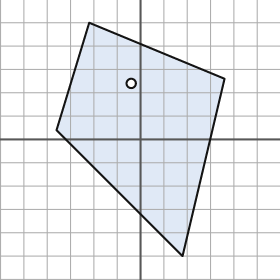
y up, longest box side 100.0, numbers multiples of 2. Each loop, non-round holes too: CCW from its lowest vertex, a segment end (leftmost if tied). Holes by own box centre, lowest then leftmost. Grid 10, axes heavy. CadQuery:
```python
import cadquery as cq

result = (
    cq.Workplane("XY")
    .moveTo(18.0, -50.0)
    .lineTo(36.0, 26.0)
    .lineTo(-22.0, 50.0)
    .lineTo(-36.0, 4.0)
    .close()
    .moveTo(-4.0, 24.0)
    .circle(2.0)
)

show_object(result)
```